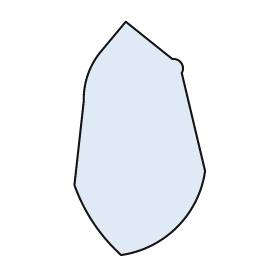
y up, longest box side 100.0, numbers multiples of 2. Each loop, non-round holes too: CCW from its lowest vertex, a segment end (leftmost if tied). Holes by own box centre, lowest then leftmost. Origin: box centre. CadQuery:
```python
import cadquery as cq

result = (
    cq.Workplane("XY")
    .moveTo(-8.0, -50.0)
    .threePointArc((16.0, -38.0), (28.0, -14.0))
    .lineTo(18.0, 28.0)
    .threePointArc((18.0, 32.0), (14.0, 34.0))
    .lineTo(-6.0, 50.0)
    .lineTo(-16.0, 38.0)
    .threePointArc((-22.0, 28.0), (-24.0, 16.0))
    .lineTo(-28.0, -20.0)
    .threePointArc((-20.0, -36.0), (-8.0, -50.0))
    .close()
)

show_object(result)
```